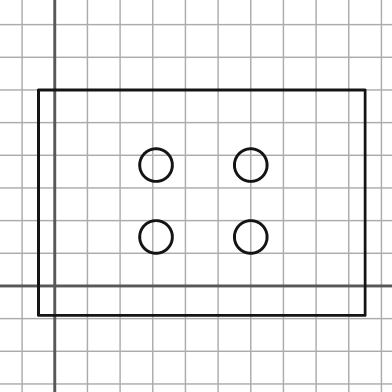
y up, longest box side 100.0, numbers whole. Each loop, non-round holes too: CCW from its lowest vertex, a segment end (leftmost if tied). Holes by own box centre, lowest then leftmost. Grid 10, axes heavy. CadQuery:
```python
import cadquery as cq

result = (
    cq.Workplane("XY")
    .moveTo(-5.0, -9.0)
    .lineTo(95.0, -9.0)
    .lineTo(95.0, 60.0)
    .lineTo(-5.0, 60.0)
    .close()
    .moveTo(31.0, 15.0)
    .circle(5.0)
    .moveTo(60.0, 15.0)
    .circle(5.0)
    .moveTo(31.0, 37.0)
    .circle(5.0)
    .moveTo(60.0, 37.0)
    .circle(5.0)
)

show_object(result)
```